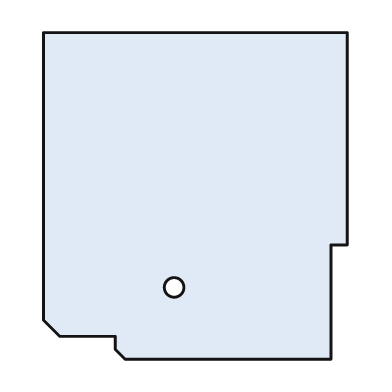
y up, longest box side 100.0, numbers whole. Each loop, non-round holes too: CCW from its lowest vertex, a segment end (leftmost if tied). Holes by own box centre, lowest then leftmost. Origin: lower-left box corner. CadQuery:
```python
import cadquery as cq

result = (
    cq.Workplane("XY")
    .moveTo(25.0, 0.0)
    .lineTo(88.0, 0.0)
    .lineTo(88.0, 35.0)
    .lineTo(93.0, 35.0)
    .lineTo(93.0, 100.0)
    .lineTo(0.0, 100.0)
    .lineTo(0.0, 12.0)
    .lineTo(5.0, 7.0)
    .lineTo(22.0, 7.0)
    .lineTo(22.0, 3.0)
    .close()
    .moveTo(40.0, 22.0)
    .circle(3.0)
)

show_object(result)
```